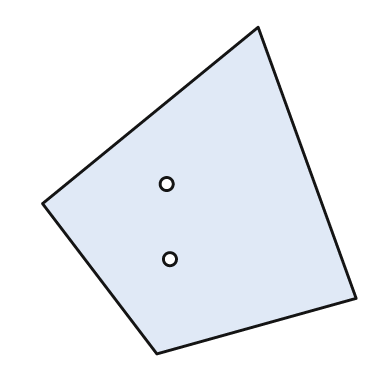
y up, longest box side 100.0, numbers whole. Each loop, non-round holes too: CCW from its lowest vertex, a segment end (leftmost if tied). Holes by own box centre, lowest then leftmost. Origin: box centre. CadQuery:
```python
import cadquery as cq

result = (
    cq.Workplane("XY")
    .moveTo(-13.0, -50.0)
    .lineTo(48.0, -33.0)
    .lineTo(18.0, 50.0)
    .lineTo(-48.0, -4.0)
    .close()
    .moveTo(-9.0, -21.0)
    .circle(2.0)
    .moveTo(-10.0, 2.0)
    .circle(2.0)
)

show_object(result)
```